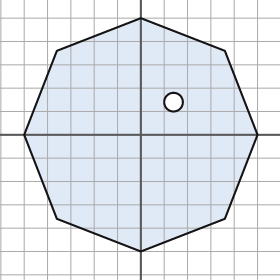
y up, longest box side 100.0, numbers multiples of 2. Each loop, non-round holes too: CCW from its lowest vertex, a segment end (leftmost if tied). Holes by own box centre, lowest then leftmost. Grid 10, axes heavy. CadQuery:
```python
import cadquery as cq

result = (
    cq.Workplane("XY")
    .moveTo(0.0, -50.0)
    .lineTo(36.0, -36.0)
    .lineTo(50.0, 0.0)
    .lineTo(36.0, 36.0)
    .lineTo(0.0, 50.0)
    .lineTo(-36.0, 36.0)
    .lineTo(-50.0, 0.0)
    .lineTo(-36.0, -36.0)
    .close()
    .moveTo(14.0, 14.0)
    .circle(4.0)
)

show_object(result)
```